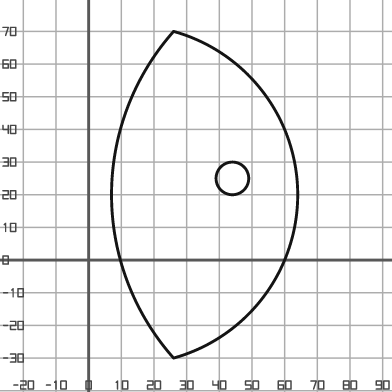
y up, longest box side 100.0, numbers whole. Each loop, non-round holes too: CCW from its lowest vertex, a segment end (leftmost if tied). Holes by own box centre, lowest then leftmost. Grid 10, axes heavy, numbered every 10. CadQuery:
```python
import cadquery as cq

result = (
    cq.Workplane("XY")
    .moveTo(26.0, -30.0)
    .threePointArc((64.0, 20.0), (26.0, 70.0))
    .threePointArc((7.0, 20.0), (26.0, -30.0))
    .close()
    .moveTo(44.0, 25.0)
    .circle(5.0)
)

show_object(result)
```